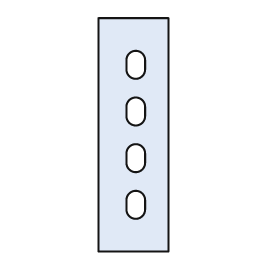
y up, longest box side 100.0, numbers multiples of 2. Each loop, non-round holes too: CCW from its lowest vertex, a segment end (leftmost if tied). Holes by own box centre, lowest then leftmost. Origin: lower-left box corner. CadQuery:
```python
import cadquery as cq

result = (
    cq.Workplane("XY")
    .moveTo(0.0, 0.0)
    .lineTo(30.0, 0.0)
    .lineTo(30.0, 100.0)
    .lineTo(0.0, 100.0)
    .close()
    .moveTo(12.0, 18.0)
    .threePointArc((16.0, 14.0), (20.0, 18.0))
    .lineTo(20.0, 22.0)
    .threePointArc((16.0, 26.0), (12.0, 22.0))
    .close()
    .moveTo(12.0, 38.0)
    .threePointArc((16.0, 34.0), (20.0, 38.0))
    .lineTo(20.0, 42.0)
    .threePointArc((16.0, 46.0), (12.0, 42.0))
    .close()
    .moveTo(12.0, 58.0)
    .threePointArc((16.0, 54.0), (20.0, 58.0))
    .lineTo(20.0, 62.0)
    .threePointArc((16.0, 66.0), (12.0, 62.0))
    .close()
    .moveTo(12.0, 78.0)
    .threePointArc((16.0, 74.0), (20.0, 78.0))
    .lineTo(20.0, 82.0)
    .threePointArc((16.0, 86.0), (12.0, 82.0))
    .close()
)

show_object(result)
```